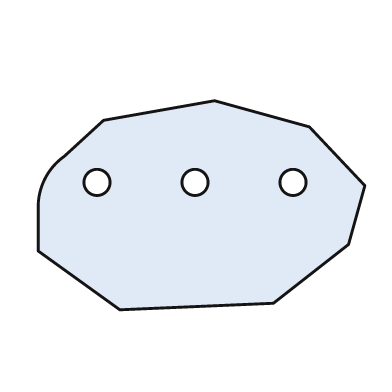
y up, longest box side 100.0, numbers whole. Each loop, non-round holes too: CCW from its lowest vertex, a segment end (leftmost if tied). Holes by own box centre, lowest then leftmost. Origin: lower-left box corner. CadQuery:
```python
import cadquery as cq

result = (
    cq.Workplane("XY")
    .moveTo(25.0, 0.0)
    .lineTo(72.0, 2.0)
    .lineTo(95.0, 20.0)
    .lineTo(100.0, 38.0)
    .lineTo(83.0, 56.0)
    .lineTo(54.0, 64.0)
    .lineTo(20.0, 58.0)
    .lineTo(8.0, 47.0)
    .threePointArc((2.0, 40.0), (0.0, 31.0))
    .lineTo(0.0, 18.0)
    .close()
    .moveTo(18.0, 39.0)
    .circle(4.0)
    .moveTo(48.0, 39.0)
    .circle(4.0)
    .moveTo(78.0, 39.0)
    .circle(4.0)
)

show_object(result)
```